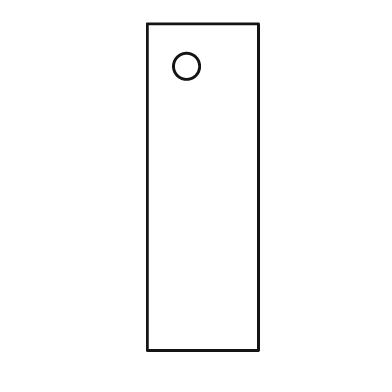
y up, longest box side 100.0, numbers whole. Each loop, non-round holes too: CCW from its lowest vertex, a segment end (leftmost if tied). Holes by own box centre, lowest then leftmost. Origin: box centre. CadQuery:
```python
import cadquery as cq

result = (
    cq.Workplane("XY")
    .moveTo(-17.0, -50.0)
    .lineTo(17.0, -50.0)
    .lineTo(17.0, 50.0)
    .lineTo(-17.0, 50.0)
    .close()
    .moveTo(-5.0, 37.0)
    .circle(4.0)
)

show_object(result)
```